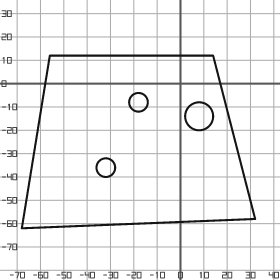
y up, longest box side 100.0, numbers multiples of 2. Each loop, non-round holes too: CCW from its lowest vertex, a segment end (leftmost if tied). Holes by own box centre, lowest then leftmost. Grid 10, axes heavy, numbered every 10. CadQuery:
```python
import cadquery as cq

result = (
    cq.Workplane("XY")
    .moveTo(-68.0, -62.0)
    .lineTo(32.0, -58.0)
    .lineTo(14.0, 12.0)
    .lineTo(-56.0, 12.0)
    .close()
    .moveTo(-32.0, -36.0)
    .circle(4.0)
    .moveTo(8.0, -14.0)
    .circle(6.0)
    .moveTo(-18.0, -8.0)
    .circle(4.0)
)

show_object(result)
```